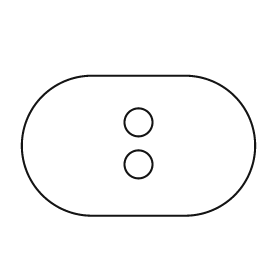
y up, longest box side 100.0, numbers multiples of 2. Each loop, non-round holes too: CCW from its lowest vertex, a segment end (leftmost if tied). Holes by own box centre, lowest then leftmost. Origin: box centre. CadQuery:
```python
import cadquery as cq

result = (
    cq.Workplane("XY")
    .moveTo(-20.0, -30.0)
    .lineTo(20.0, -30.0)
    .threePointArc((50.0, 0.0), (20.0, 30.0))
    .lineTo(-20.0, 30.0)
    .threePointArc((-50.0, 0.0), (-20.0, -30.0))
    .close()
    .moveTo(0.0, -8.0)
    .circle(6.0)
    .moveTo(0.0, 10.0)
    .circle(6.0)
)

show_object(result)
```